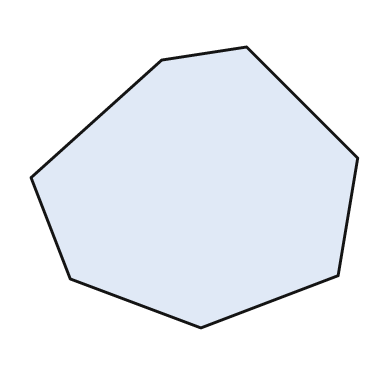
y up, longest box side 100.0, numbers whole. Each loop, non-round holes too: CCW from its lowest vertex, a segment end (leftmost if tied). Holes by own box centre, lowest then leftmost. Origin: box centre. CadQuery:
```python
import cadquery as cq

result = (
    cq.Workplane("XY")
    .moveTo(2.0, -43.0)
    .lineTo(44.0, -27.0)
    .lineTo(50.0, 9.0)
    .lineTo(16.0, 43.0)
    .lineTo(-10.0, 39.0)
    .lineTo(-50.0, 3.0)
    .lineTo(-38.0, -28.0)
    .close()
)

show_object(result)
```